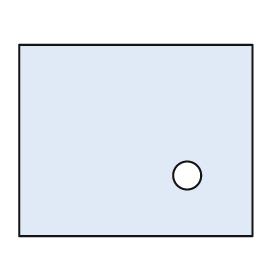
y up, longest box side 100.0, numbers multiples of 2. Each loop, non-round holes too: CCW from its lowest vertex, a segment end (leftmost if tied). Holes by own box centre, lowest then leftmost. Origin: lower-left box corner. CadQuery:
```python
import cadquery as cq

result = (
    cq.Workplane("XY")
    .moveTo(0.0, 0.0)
    .lineTo(100.0, 0.0)
    .lineTo(100.0, 82.0)
    .lineTo(0.0, 82.0)
    .close()
    .moveTo(72.0, 26.0)
    .circle(6.0)
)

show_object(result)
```